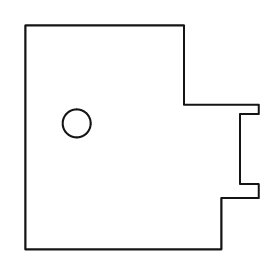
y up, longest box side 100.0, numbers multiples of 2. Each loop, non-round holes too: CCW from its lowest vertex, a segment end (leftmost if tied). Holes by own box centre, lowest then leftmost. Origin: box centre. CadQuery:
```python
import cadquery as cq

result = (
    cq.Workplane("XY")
    .moveTo(-50.0, -48.0)
    .lineTo(34.0, -48.0)
    .lineTo(34.0, -26.0)
    .lineTo(50.0, -26.0)
    .lineTo(50.0, -20.0)
    .lineTo(42.0, -20.0)
    .lineTo(42.0, 10.0)
    .lineTo(50.0, 10.0)
    .lineTo(50.0, 14.0)
    .lineTo(18.0, 14.0)
    .lineTo(18.0, 48.0)
    .lineTo(-50.0, 48.0)
    .close()
    .moveTo(-28.0, 6.0)
    .circle(6.0)
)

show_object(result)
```